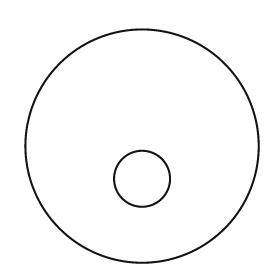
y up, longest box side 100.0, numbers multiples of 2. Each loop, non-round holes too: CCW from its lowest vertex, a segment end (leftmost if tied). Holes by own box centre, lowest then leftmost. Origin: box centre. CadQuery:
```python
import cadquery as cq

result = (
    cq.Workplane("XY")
    .moveTo(0.0, 0.0)
    .circle(50.0)
    .moveTo(0.0, -14.0)
    .circle(12.0)
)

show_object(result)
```